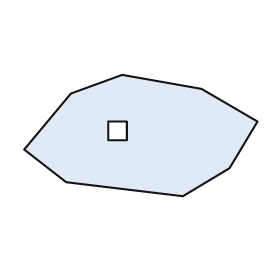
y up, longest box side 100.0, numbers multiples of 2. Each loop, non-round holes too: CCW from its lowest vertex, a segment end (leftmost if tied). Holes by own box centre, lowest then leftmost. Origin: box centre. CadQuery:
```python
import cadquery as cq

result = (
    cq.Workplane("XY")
    .moveTo(18.0, -26.0)
    .lineTo(38.0, -14.0)
    .lineTo(50.0, 6.0)
    .lineTo(26.0, 20.0)
    .lineTo(-8.0, 26.0)
    .lineTo(-30.0, 18.0)
    .lineTo(-50.0, -6.0)
    .lineTo(-32.0, -20.0)
    .close()
    .moveTo(-14.0, -2.0)
    .lineTo(-6.0, -2.0)
    .lineTo(-6.0, 6.0)
    .lineTo(-14.0, 6.0)
    .close()
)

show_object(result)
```